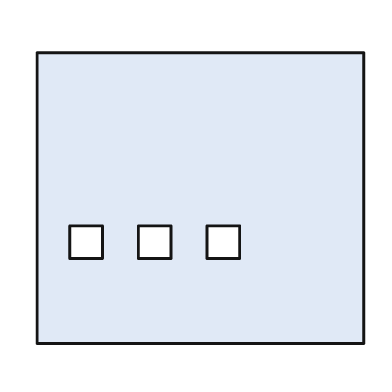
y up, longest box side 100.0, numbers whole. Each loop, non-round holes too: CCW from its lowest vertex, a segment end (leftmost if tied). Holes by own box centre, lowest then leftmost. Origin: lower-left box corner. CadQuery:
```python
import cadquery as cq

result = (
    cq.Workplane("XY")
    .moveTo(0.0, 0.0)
    .lineTo(100.0, 0.0)
    .lineTo(100.0, 89.0)
    .lineTo(0.0, 89.0)
    .close()
    .moveTo(10.0, 26.0)
    .lineTo(20.0, 26.0)
    .lineTo(20.0, 36.0)
    .lineTo(10.0, 36.0)
    .close()
    .moveTo(31.0, 26.0)
    .lineTo(41.0, 26.0)
    .lineTo(41.0, 36.0)
    .lineTo(31.0, 36.0)
    .close()
    .moveTo(52.0, 26.0)
    .lineTo(62.0, 26.0)
    .lineTo(62.0, 36.0)
    .lineTo(52.0, 36.0)
    .close()
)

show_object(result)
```